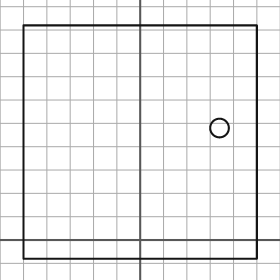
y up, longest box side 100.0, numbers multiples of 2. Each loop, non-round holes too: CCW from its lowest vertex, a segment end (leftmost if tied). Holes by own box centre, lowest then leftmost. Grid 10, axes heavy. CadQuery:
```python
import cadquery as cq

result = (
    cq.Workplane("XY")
    .moveTo(-50.0, -8.0)
    .lineTo(50.0, -8.0)
    .lineTo(50.0, 92.0)
    .lineTo(-50.0, 92.0)
    .close()
    .moveTo(34.0, 48.0)
    .circle(4.0)
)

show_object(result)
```